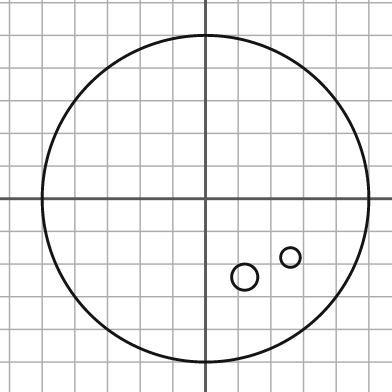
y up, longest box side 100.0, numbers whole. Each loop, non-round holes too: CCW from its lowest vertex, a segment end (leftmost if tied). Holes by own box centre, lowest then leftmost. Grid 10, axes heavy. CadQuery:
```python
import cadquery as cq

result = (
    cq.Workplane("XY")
    .moveTo(0.0, 0.0)
    .circle(50.0)
    .moveTo(12.0, -24.0)
    .circle(4.0)
    .moveTo(26.0, -18.0)
    .circle(3.0)
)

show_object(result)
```